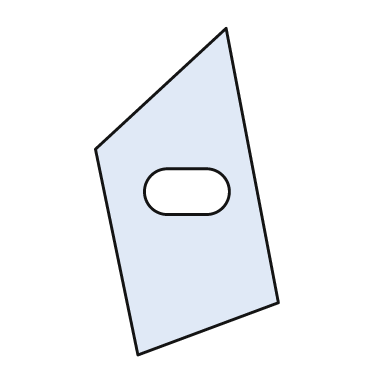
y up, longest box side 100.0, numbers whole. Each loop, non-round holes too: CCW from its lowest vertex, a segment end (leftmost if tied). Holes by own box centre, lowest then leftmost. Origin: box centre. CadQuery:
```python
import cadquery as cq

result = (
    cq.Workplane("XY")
    .moveTo(-15.0, -50.0)
    .lineTo(28.0, -34.0)
    .lineTo(12.0, 50.0)
    .lineTo(-28.0, 13.0)
    .close()
    .moveTo(-6.0, -7.0)
    .lineTo(6.0, -7.0)
    .threePointArc((13.0, 0.0), (6.0, 7.0))
    .lineTo(-6.0, 7.0)
    .threePointArc((-13.0, 0.0), (-6.0, -7.0))
    .close()
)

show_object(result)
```